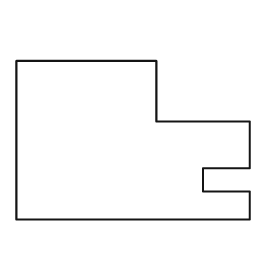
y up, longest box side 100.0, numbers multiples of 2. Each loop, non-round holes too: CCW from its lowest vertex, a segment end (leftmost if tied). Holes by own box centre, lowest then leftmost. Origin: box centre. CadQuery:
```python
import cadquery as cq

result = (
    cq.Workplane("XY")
    .moveTo(-50.0, -34.0)
    .lineTo(50.0, -34.0)
    .lineTo(50.0, -22.0)
    .lineTo(30.0, -22.0)
    .lineTo(30.0, -12.0)
    .lineTo(50.0, -12.0)
    .lineTo(50.0, 8.0)
    .lineTo(10.0, 8.0)
    .lineTo(10.0, 34.0)
    .lineTo(-50.0, 34.0)
    .close()
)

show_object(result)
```